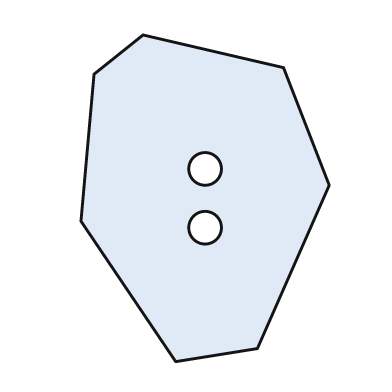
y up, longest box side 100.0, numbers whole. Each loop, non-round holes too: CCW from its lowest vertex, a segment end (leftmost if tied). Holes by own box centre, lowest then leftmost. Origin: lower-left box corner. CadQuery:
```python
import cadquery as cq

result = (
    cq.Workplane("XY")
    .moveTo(29.0, 0.0)
    .lineTo(54.0, 4.0)
    .lineTo(76.0, 54.0)
    .lineTo(62.0, 90.0)
    .lineTo(19.0, 100.0)
    .lineTo(4.0, 88.0)
    .lineTo(0.0, 43.0)
    .close()
    .moveTo(38.0, 41.0)
    .circle(5.0)
    .moveTo(38.0, 59.0)
    .circle(5.0)
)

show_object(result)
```